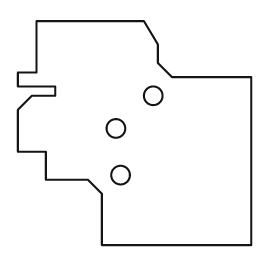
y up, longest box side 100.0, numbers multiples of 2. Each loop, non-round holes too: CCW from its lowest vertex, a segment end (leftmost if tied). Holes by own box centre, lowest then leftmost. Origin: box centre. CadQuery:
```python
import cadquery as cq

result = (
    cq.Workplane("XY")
    .moveTo(-14.0, -48.0)
    .lineTo(50.0, -48.0)
    .lineTo(50.0, 24.0)
    .lineTo(16.0, 24.0)
    .lineTo(10.0, 30.0)
    .lineTo(10.0, 38.0)
    .lineTo(4.0, 48.0)
    .lineTo(-42.0, 48.0)
    .lineTo(-42.0, 26.0)
    .lineTo(-50.0, 26.0)
    .lineTo(-50.0, 20.0)
    .lineTo(-34.0, 20.0)
    .lineTo(-34.0, 16.0)
    .lineTo(-44.0, 16.0)
    .lineTo(-50.0, 10.0)
    .lineTo(-50.0, -8.0)
    .lineTo(-38.0, -8.0)
    .lineTo(-38.0, -20.0)
    .lineTo(-20.0, -20.0)
    .lineTo(-14.0, -26.0)
    .close()
    .moveTo(-6.0, -18.0)
    .circle(4.0)
    .moveTo(-8.0, 2.0)
    .circle(4.0)
    .moveTo(8.0, 16.0)
    .circle(4.0)
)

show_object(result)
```